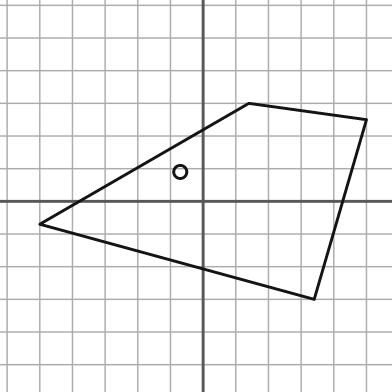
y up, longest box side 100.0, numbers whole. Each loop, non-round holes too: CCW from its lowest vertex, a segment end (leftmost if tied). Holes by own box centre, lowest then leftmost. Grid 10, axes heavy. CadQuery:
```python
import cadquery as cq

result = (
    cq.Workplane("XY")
    .moveTo(34.0, -30.0)
    .lineTo(50.0, 25.0)
    .lineTo(14.0, 30.0)
    .lineTo(-50.0, -7.0)
    .close()
    .moveTo(-7.0, 9.0)
    .circle(2.0)
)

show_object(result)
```